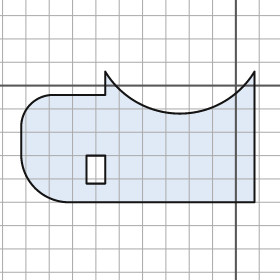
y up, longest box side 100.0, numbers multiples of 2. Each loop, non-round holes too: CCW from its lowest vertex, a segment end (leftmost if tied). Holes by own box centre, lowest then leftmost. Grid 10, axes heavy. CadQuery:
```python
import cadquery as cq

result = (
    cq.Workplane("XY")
    .moveTo(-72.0, -50.0)
    .lineTo(8.0, -50.0)
    .lineTo(8.0, 6.0)
    .threePointArc((-24.0, -12.0), (-56.0, 6.0))
    .lineTo(-56.0, -4.0)
    .lineTo(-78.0, -4.0)
    .threePointArc((-88.0, -8.0), (-92.0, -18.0))
    .lineTo(-92.0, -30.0)
    .threePointArc((-86.0, -44.0), (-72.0, -50.0))
    .close()
    .moveTo(-64.0, -42.0)
    .lineTo(-56.0, -42.0)
    .lineTo(-56.0, -30.0)
    .lineTo(-64.0, -30.0)
    .close()
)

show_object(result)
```